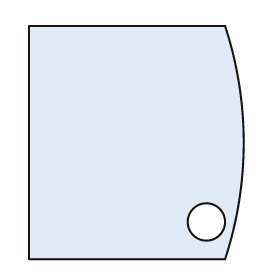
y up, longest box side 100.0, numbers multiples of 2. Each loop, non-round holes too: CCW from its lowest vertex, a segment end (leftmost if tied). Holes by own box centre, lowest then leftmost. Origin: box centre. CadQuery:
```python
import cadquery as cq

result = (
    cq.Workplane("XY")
    .moveTo(-46.0, -50.0)
    .lineTo(38.0, -50.0)
    .threePointArc((46.0, 0.0), (38.0, 50.0))
    .lineTo(-46.0, 50.0)
    .close()
    .moveTo(30.0, -34.0)
    .circle(8.0)
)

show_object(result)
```